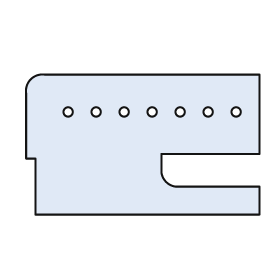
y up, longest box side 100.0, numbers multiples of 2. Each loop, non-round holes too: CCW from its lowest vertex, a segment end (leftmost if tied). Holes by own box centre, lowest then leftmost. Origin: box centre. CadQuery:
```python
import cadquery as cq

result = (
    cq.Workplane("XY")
    .moveTo(-46.0, -30.0)
    .lineTo(50.0, -30.0)
    .lineTo(50.0, -18.0)
    .lineTo(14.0, -18.0)
    .threePointArc((10.0, -16.0), (8.0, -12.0))
    .lineTo(8.0, -4.0)
    .lineTo(50.0, -4.0)
    .lineTo(50.0, 30.0)
    .lineTo(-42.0, 30.0)
    .threePointArc((-48.0, 28.0), (-50.0, 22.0))
    .lineTo(-50.0, -6.0)
    .lineTo(-46.0, -6.0)
    .close()
    .moveTo(-32.0, 14.0)
    .circle(2.0)
    .moveTo(-20.0, 14.0)
    .circle(2.0)
    .moveTo(-8.0, 14.0)
    .circle(2.0)
    .moveTo(4.0, 14.0)
    .circle(2.0)
    .moveTo(16.0, 14.0)
    .circle(2.0)
    .moveTo(28.0, 14.0)
    .circle(2.0)
    .moveTo(40.0, 14.0)
    .circle(2.0)
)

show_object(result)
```